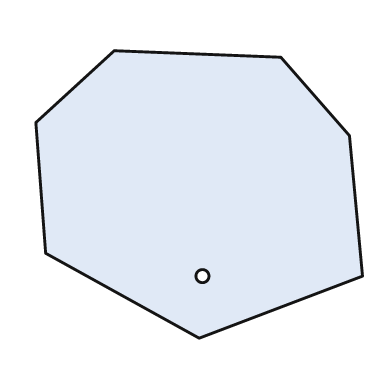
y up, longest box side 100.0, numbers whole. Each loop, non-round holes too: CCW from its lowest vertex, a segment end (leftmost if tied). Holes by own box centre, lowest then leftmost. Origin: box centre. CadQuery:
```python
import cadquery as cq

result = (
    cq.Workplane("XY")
    .moveTo(0.0, -44.0)
    .lineTo(50.0, -25.0)
    .lineTo(46.0, 18.0)
    .lineTo(25.0, 42.0)
    .lineTo(-26.0, 44.0)
    .lineTo(-50.0, 22.0)
    .lineTo(-47.0, -18.0)
    .close()
    .moveTo(1.0, -25.0)
    .circle(2.0)
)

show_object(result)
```